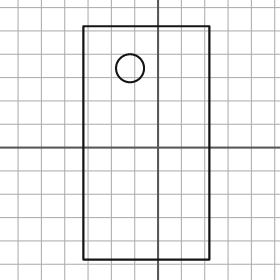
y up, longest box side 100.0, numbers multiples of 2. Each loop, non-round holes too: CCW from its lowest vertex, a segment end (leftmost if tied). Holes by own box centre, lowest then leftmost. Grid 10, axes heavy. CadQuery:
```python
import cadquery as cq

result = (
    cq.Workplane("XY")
    .moveTo(-32.0, -48.0)
    .lineTo(22.0, -48.0)
    .lineTo(22.0, 52.0)
    .lineTo(-32.0, 52.0)
    .close()
    .moveTo(-12.0, 34.0)
    .circle(6.0)
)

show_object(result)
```